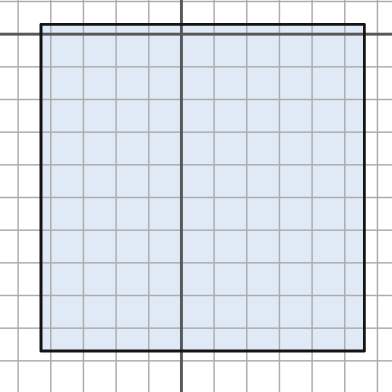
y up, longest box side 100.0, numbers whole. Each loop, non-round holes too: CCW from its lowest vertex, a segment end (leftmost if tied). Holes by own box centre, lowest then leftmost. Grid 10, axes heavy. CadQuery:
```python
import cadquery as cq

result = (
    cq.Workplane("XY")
    .moveTo(-43.0, -97.0)
    .lineTo(56.0, -97.0)
    .lineTo(56.0, 3.0)
    .lineTo(-43.0, 3.0)
    .close()
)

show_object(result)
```